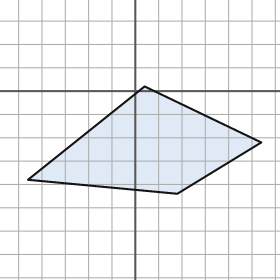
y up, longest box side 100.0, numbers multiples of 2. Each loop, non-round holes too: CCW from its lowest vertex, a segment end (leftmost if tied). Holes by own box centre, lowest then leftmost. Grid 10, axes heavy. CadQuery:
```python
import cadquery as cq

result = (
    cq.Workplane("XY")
    .moveTo(18.0, -44.0)
    .lineTo(54.0, -22.0)
    .lineTo(4.0, 2.0)
    .lineTo(-46.0, -38.0)
    .close()
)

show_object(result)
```